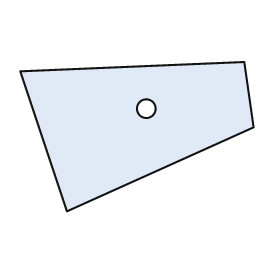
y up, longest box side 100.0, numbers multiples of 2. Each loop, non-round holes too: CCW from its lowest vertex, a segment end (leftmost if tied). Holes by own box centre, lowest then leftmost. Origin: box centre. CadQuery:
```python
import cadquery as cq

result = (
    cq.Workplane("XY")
    .moveTo(-30.0, -32.0)
    .lineTo(50.0, 4.0)
    .lineTo(46.0, 32.0)
    .lineTo(-50.0, 28.0)
    .close()
    .moveTo(4.0, 12.0)
    .circle(4.0)
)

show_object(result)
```